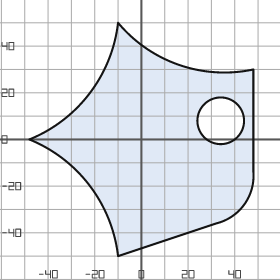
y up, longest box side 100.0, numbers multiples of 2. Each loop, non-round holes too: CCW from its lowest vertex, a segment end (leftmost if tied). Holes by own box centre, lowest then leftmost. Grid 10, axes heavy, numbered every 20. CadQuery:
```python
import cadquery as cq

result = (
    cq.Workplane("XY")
    .moveTo(-10.0, -50.0)
    .lineTo(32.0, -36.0)
    .threePointArc((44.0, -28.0), (48.0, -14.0))
    .lineTo(48.0, 30.0)
    .threePointArc((16.0, 32.0), (-10.0, 50.0))
    .threePointArc((-22.0, 20.0), (-48.0, 0.0))
    .threePointArc((-22.0, -20.0), (-10.0, -50.0))
    .close()
    .moveTo(34.0, 8.0)
    .circle(10.0)
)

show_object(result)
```